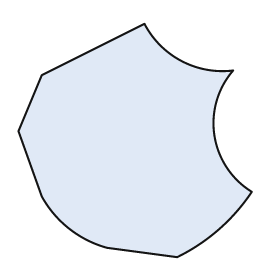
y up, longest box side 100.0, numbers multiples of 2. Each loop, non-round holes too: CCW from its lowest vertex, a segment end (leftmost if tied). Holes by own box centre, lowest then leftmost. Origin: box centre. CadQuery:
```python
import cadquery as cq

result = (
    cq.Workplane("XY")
    .moveTo(18.0, -50.0)
    .threePointArc((36.0, -38.0), (50.0, -22.0))
    .threePointArc((34.0, 2.0), (42.0, 30.0))
    .threePointArc((20.0, 34.0), (4.0, 50.0))
    .lineTo(-40.0, 28.0)
    .lineTo(-50.0, 4.0)
    .lineTo(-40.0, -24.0)
    .threePointArc((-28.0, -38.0), (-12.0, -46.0))
    .close()
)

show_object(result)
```